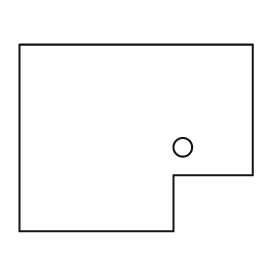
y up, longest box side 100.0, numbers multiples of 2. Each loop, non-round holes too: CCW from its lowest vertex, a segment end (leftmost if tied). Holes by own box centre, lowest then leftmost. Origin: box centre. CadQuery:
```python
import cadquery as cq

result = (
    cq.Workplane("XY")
    .moveTo(-50.0, -40.0)
    .lineTo(16.0, -40.0)
    .lineTo(16.0, -16.0)
    .lineTo(50.0, -16.0)
    .lineTo(50.0, 40.0)
    .lineTo(-50.0, 40.0)
    .close()
    .moveTo(20.0, -4.0)
    .circle(4.0)
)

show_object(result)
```